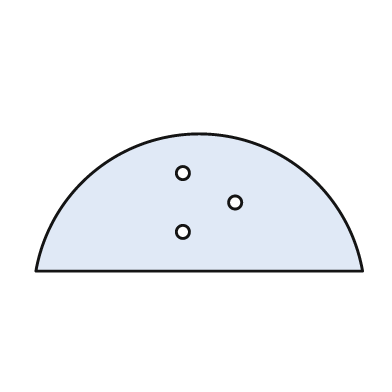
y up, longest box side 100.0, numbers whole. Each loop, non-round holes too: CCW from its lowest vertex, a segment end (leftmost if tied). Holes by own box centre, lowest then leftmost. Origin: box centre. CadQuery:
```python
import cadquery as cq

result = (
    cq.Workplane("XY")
    .moveTo(-50.0, -21.0)
    .lineTo(50.0, -21.0)
    .threePointArc((0.0, 21.0), (-50.0, -21.0))
    .close()
    .moveTo(-5.0, -9.0)
    .circle(2.0)
    .moveTo(11.0, 0.0)
    .circle(2.0)
    .moveTo(-5.0, 9.0)
    .circle(2.0)
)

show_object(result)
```